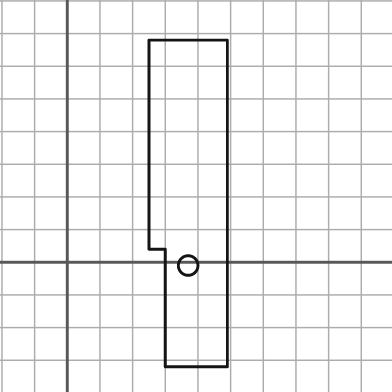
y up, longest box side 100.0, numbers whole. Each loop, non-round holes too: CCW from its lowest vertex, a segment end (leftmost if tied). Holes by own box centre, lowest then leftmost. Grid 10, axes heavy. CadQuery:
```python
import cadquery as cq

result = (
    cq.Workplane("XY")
    .moveTo(30.0, -32.0)
    .lineTo(49.0, -32.0)
    .lineTo(49.0, 68.0)
    .lineTo(25.0, 68.0)
    .lineTo(25.0, 4.0)
    .lineTo(30.0, 4.0)
    .close()
    .moveTo(37.0, -1.0)
    .circle(3.0)
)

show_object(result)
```